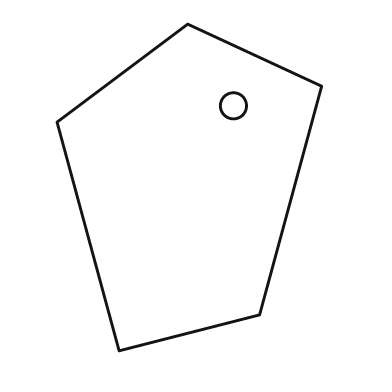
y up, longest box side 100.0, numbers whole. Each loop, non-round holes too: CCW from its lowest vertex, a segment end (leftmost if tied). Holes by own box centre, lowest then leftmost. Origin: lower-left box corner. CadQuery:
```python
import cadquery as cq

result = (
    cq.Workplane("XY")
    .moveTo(19.0, 0.0)
    .lineTo(62.0, 11.0)
    .lineTo(81.0, 81.0)
    .lineTo(40.0, 100.0)
    .lineTo(0.0, 70.0)
    .close()
    .moveTo(54.0, 75.0)
    .circle(4.0)
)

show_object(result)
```